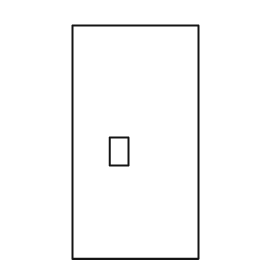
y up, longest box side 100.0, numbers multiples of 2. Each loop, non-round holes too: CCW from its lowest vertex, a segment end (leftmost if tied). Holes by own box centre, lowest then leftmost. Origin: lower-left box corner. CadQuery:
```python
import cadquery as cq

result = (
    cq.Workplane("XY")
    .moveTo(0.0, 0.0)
    .lineTo(54.0, 0.0)
    .lineTo(54.0, 100.0)
    .lineTo(0.0, 100.0)
    .close()
    .moveTo(16.0, 40.0)
    .lineTo(24.0, 40.0)
    .lineTo(24.0, 52.0)
    .lineTo(16.0, 52.0)
    .close()
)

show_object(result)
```